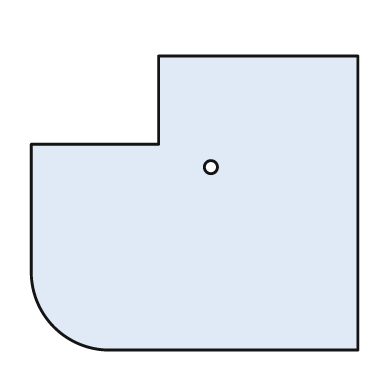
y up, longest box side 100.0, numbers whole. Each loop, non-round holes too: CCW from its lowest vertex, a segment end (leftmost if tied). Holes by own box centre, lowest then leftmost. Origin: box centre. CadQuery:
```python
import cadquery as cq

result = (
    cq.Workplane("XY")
    .moveTo(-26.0, -45.0)
    .lineTo(50.0, -45.0)
    .lineTo(50.0, 45.0)
    .lineTo(-11.0, 45.0)
    .lineTo(-11.0, 18.0)
    .lineTo(-50.0, 18.0)
    .lineTo(-50.0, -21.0)
    .threePointArc((-43.0, -38.0), (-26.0, -45.0))
    .close()
    .moveTo(5.0, 11.0)
    .circle(2.0)
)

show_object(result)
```